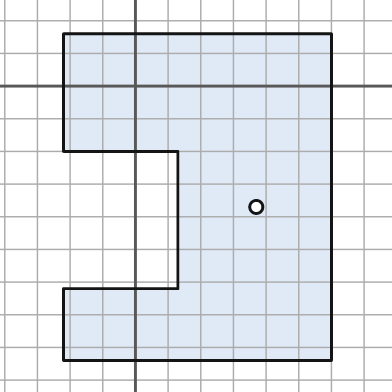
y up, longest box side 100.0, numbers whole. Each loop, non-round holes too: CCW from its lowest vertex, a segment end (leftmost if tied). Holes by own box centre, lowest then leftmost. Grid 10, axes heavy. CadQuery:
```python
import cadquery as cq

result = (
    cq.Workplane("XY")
    .moveTo(-22.0, -84.0)
    .lineTo(60.0, -84.0)
    .lineTo(60.0, 16.0)
    .lineTo(-22.0, 16.0)
    .lineTo(-22.0, -20.0)
    .lineTo(13.0, -20.0)
    .lineTo(13.0, -62.0)
    .lineTo(-22.0, -62.0)
    .close()
    .moveTo(37.0, -37.0)
    .circle(2.0)
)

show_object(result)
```